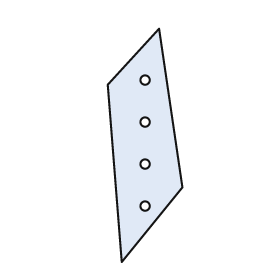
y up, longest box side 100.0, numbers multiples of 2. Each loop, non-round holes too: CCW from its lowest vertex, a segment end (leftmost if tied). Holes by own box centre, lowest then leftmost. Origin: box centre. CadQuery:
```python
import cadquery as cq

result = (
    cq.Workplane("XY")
    .moveTo(-10.0, -50.0)
    .lineTo(16.0, -18.0)
    .lineTo(6.0, 50.0)
    .lineTo(-16.0, 26.0)
    .close()
    .moveTo(0.0, -26.0)
    .circle(2.0)
    .moveTo(0.0, -8.0)
    .circle(2.0)
    .moveTo(0.0, 10.0)
    .circle(2.0)
    .moveTo(0.0, 28.0)
    .circle(2.0)
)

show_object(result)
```